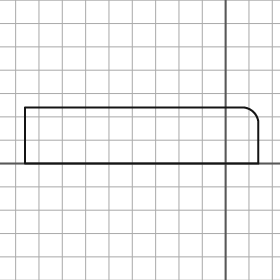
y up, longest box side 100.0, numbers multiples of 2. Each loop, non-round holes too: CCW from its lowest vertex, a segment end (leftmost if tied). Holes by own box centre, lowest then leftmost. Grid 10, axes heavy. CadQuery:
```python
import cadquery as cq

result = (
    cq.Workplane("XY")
    .moveTo(-86.0, 0.0)
    .lineTo(14.0, 0.0)
    .lineTo(14.0, 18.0)
    .threePointArc((12.0, 22.0), (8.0, 24.0))
    .lineTo(-86.0, 24.0)
    .close()
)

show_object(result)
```